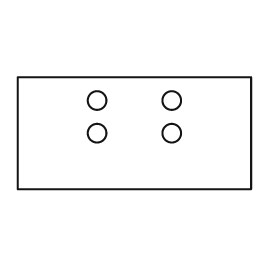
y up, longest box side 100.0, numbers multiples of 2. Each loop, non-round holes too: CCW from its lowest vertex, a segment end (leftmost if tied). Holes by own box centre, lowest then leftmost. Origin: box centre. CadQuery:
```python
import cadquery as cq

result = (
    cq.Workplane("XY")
    .moveTo(-50.0, -24.0)
    .lineTo(50.0, -24.0)
    .lineTo(50.0, 24.0)
    .lineTo(-50.0, 24.0)
    .close()
    .moveTo(-16.0, 0.0)
    .circle(4.0)
    .moveTo(16.0, 0.0)
    .circle(4.0)
    .moveTo(-16.0, 14.0)
    .circle(4.0)
    .moveTo(16.0, 14.0)
    .circle(4.0)
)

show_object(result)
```